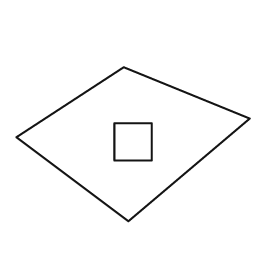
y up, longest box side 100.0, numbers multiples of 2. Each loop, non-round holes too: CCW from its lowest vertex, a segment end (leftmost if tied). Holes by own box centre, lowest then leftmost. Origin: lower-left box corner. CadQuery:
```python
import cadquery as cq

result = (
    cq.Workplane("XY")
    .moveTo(48.0, 0.0)
    .lineTo(100.0, 44.0)
    .lineTo(46.0, 66.0)
    .lineTo(0.0, 36.0)
    .close()
    .moveTo(42.0, 26.0)
    .lineTo(58.0, 26.0)
    .lineTo(58.0, 42.0)
    .lineTo(42.0, 42.0)
    .close()
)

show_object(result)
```